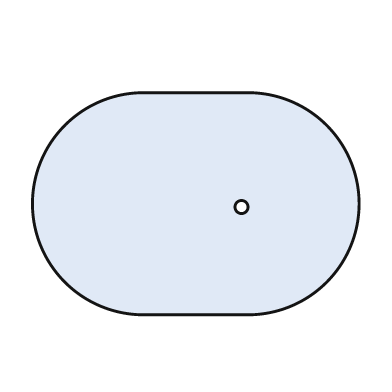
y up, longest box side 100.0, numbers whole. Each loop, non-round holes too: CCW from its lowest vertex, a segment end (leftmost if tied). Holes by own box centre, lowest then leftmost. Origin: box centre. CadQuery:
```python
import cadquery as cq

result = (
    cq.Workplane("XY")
    .moveTo(-16.0, -34.0)
    .lineTo(16.0, -34.0)
    .threePointArc((50.0, 0.0), (16.0, 34.0))
    .lineTo(-16.0, 34.0)
    .threePointArc((-50.0, 0.0), (-16.0, -34.0))
    .close()
    .moveTo(14.0, -1.0)
    .circle(2.0)
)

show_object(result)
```